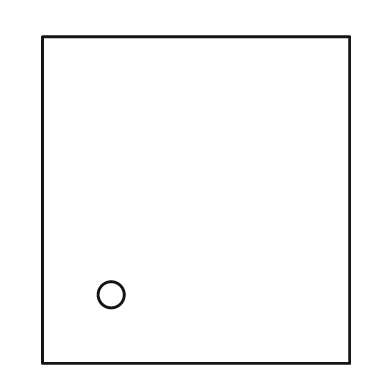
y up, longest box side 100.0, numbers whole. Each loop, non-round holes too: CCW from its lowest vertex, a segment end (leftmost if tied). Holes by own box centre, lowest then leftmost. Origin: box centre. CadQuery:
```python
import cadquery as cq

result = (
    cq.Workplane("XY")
    .moveTo(-47.0, -50.0)
    .lineTo(47.0, -50.0)
    .lineTo(47.0, 50.0)
    .lineTo(-47.0, 50.0)
    .close()
    .moveTo(-26.0, -29.0)
    .circle(4.0)
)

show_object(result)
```